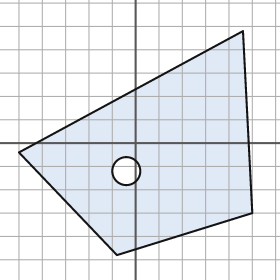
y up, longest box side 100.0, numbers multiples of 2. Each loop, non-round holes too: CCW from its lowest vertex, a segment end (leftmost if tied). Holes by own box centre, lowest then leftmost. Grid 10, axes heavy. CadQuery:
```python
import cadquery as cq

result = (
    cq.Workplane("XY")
    .moveTo(-8.0, -48.0)
    .lineTo(50.0, -30.0)
    .lineTo(46.0, 48.0)
    .lineTo(-50.0, -4.0)
    .close()
    .moveTo(-4.0, -12.0)
    .circle(6.0)
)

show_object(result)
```